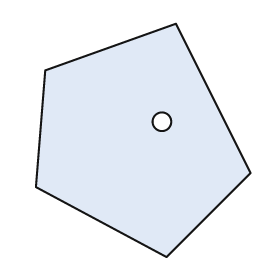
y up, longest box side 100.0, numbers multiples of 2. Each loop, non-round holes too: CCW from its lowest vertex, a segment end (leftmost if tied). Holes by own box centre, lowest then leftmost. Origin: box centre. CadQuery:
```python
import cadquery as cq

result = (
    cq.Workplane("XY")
    .moveTo(10.0, -50.0)
    .lineTo(46.0, -14.0)
    .lineTo(14.0, 50.0)
    .lineTo(-42.0, 30.0)
    .lineTo(-46.0, -20.0)
    .close()
    .moveTo(8.0, 8.0)
    .circle(4.0)
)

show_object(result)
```